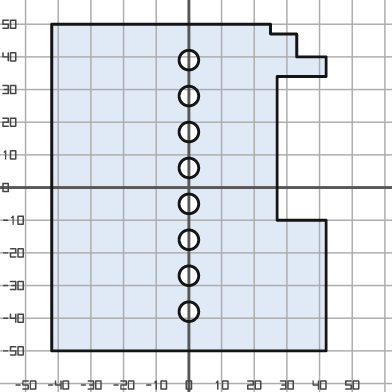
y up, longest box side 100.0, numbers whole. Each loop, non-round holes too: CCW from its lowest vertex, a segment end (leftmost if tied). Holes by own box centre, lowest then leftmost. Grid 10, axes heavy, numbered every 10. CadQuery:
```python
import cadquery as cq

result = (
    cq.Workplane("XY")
    .moveTo(-42.0, -50.0)
    .lineTo(42.0, -50.0)
    .lineTo(42.0, -10.0)
    .lineTo(27.0, -10.0)
    .lineTo(27.0, 34.0)
    .lineTo(42.0, 34.0)
    .lineTo(42.0, 40.0)
    .lineTo(33.0, 40.0)
    .lineTo(33.0, 47.0)
    .lineTo(25.0, 47.0)
    .lineTo(25.0, 50.0)
    .lineTo(-42.0, 50.0)
    .close()
    .moveTo(0.0, -38.0)
    .circle(3.0)
    .moveTo(0.0, -27.0)
    .circle(3.0)
    .moveTo(0.0, -16.0)
    .circle(3.0)
    .moveTo(0.0, -5.0)
    .circle(3.0)
    .moveTo(0.0, 6.0)
    .circle(3.0)
    .moveTo(0.0, 17.0)
    .circle(3.0)
    .moveTo(0.0, 28.0)
    .circle(3.0)
    .moveTo(0.0, 39.0)
    .circle(3.0)
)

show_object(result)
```